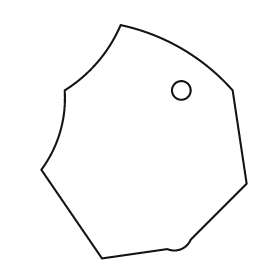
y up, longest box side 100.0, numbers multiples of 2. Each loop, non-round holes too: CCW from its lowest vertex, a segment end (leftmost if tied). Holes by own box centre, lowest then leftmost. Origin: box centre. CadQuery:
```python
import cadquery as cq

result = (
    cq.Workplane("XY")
    .moveTo(-18.0, -50.0)
    .lineTo(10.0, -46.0)
    .threePointArc((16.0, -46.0), (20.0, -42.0))
    .lineTo(44.0, -18.0)
    .lineTo(38.0, 22.0)
    .threePointArc((16.0, 40.0), (-10.0, 50.0))
    .threePointArc((-20.0, 34.0), (-34.0, 22.0))
    .threePointArc((-36.0, 4.0), (-44.0, -12.0))
    .close()
    .moveTo(16.0, 22.0)
    .circle(4.0)
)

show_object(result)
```